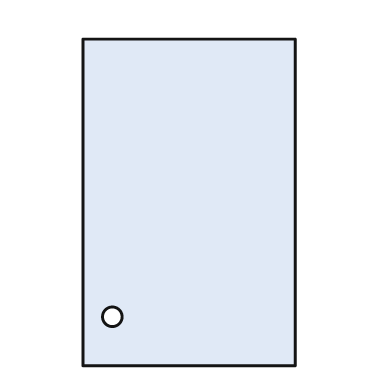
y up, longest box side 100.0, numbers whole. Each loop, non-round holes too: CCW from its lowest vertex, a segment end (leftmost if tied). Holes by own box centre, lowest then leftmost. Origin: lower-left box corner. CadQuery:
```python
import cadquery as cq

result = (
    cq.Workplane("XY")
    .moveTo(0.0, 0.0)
    .lineTo(65.0, 0.0)
    .lineTo(65.0, 100.0)
    .lineTo(0.0, 100.0)
    .close()
    .moveTo(9.0, 15.0)
    .circle(3.0)
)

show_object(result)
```